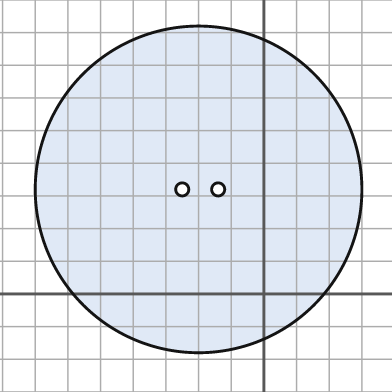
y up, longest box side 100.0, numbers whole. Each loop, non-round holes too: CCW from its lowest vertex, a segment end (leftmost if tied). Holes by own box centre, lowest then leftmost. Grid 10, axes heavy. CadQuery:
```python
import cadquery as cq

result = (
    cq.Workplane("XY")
    .moveTo(-20.0, 32.0)
    .circle(50.0)
    .moveTo(-25.0, 32.0)
    .circle(2.0)
    .moveTo(-14.0, 32.0)
    .circle(2.0)
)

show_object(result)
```